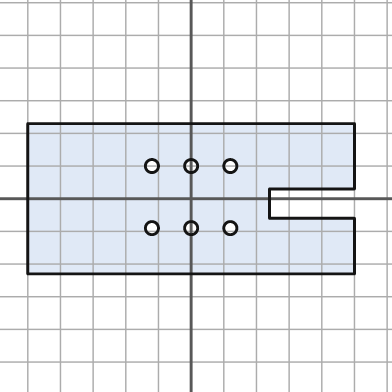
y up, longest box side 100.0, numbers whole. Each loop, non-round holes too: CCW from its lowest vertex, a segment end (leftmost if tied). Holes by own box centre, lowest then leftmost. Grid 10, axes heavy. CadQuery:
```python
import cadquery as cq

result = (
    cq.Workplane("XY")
    .moveTo(-50.0, -23.0)
    .lineTo(50.0, -23.0)
    .lineTo(50.0, -6.0)
    .lineTo(24.0, -6.0)
    .lineTo(24.0, 3.0)
    .lineTo(50.0, 3.0)
    .lineTo(50.0, 23.0)
    .lineTo(-50.0, 23.0)
    .close()
    .moveTo(-12.0, -9.0)
    .circle(2.0)
    .moveTo(0.0, -9.0)
    .circle(2.0)
    .moveTo(12.0, -9.0)
    .circle(2.0)
    .moveTo(-12.0, 10.0)
    .circle(2.0)
    .moveTo(0.0, 10.0)
    .circle(2.0)
    .moveTo(12.0, 10.0)
    .circle(2.0)
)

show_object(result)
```